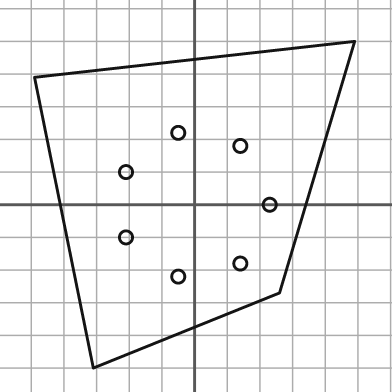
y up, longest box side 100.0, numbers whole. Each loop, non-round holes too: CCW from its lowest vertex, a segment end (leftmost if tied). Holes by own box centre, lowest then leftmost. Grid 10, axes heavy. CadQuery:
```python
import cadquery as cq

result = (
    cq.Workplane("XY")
    .moveTo(-31.0, -50.0)
    .lineTo(26.0, -27.0)
    .lineTo(49.0, 50.0)
    .lineTo(-49.0, 39.0)
    .close()
    .moveTo(-5.0, -22.0)
    .circle(2.0)
    .moveTo(14.0, -18.0)
    .circle(2.0)
    .moveTo(-21.0, -10.0)
    .circle(2.0)
    .moveTo(23.0, 0.0)
    .circle(2.0)
    .moveTo(-21.0, 10.0)
    .circle(2.0)
    .moveTo(14.0, 18.0)
    .circle(2.0)
    .moveTo(-5.0, 22.0)
    .circle(2.0)
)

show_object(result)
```